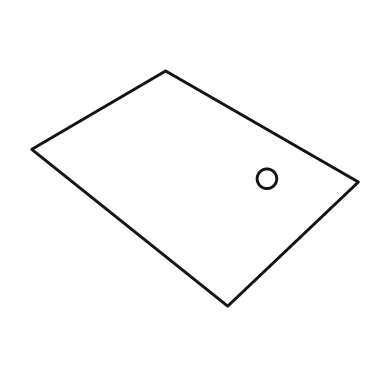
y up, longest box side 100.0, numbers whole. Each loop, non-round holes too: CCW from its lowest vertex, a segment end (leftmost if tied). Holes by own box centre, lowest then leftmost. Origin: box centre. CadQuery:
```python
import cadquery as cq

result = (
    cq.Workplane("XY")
    .moveTo(10.0, -36.0)
    .lineTo(50.0, 2.0)
    .lineTo(-9.0, 36.0)
    .lineTo(-50.0, 12.0)
    .close()
    .moveTo(22.0, 3.0)
    .circle(3.0)
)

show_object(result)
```